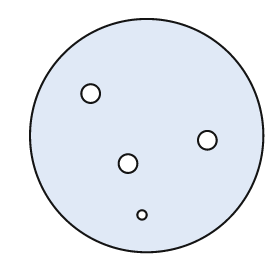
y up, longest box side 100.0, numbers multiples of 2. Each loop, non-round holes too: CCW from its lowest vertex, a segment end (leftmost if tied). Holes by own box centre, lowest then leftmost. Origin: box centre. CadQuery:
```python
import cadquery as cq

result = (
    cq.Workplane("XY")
    .moveTo(0.0, 0.0)
    .circle(50.0)
    .moveTo(-2.0, -34.0)
    .circle(2.0)
    .moveTo(-8.0, -12.0)
    .circle(4.0)
    .moveTo(26.0, -2.0)
    .circle(4.0)
    .moveTo(-24.0, 18.0)
    .circle(4.0)
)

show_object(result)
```